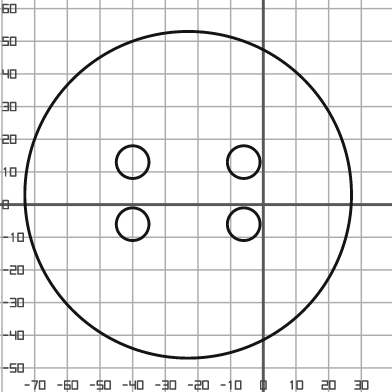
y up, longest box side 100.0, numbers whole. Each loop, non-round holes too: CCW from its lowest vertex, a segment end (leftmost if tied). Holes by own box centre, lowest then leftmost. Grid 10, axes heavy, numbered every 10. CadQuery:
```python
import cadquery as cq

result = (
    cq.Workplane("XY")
    .moveTo(-23.0, 3.0)
    .circle(50.0)
    .moveTo(-40.0, -6.0)
    .circle(5.0)
    .moveTo(-6.0, -6.0)
    .circle(5.0)
    .moveTo(-40.0, 13.0)
    .circle(5.0)
    .moveTo(-6.0, 13.0)
    .circle(5.0)
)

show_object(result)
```